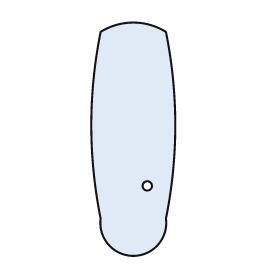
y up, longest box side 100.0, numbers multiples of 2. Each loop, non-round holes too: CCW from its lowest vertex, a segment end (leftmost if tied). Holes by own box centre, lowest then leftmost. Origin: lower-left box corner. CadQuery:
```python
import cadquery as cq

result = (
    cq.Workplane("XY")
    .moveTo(4.0, 16.0)
    .threePointArc((18.0, 0.0), (32.0, 16.0))
    .threePointArc((36.0, 56.0), (32.0, 96.0))
    .threePointArc((18.0, 100.0), (4.0, 96.0))
    .threePointArc((0.0, 56.0), (4.0, 16.0))
    .close()
    .moveTo(24.0, 30.0)
    .circle(2.0)
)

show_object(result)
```